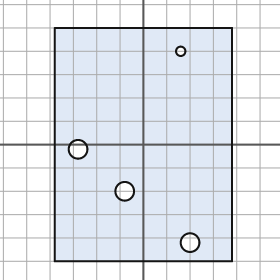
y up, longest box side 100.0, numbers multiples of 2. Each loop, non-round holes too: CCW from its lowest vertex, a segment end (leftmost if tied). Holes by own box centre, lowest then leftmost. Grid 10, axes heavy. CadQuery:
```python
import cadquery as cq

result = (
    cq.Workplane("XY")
    .moveTo(-38.0, -50.0)
    .lineTo(38.0, -50.0)
    .lineTo(38.0, 50.0)
    .lineTo(-38.0, 50.0)
    .close()
    .moveTo(20.0, -42.0)
    .circle(4.0)
    .moveTo(-8.0, -20.0)
    .circle(4.0)
    .moveTo(-28.0, -2.0)
    .circle(4.0)
    .moveTo(16.0, 40.0)
    .circle(2.0)
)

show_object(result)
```